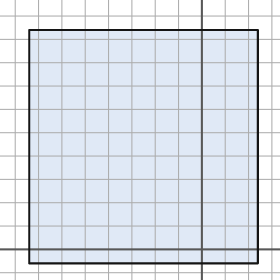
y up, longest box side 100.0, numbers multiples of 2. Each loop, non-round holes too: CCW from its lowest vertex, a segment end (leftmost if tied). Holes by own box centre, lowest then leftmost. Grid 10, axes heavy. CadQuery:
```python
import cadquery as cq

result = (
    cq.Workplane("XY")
    .moveTo(-74.0, -6.0)
    .lineTo(24.0, -6.0)
    .lineTo(24.0, 94.0)
    .lineTo(-74.0, 94.0)
    .close()
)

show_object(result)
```